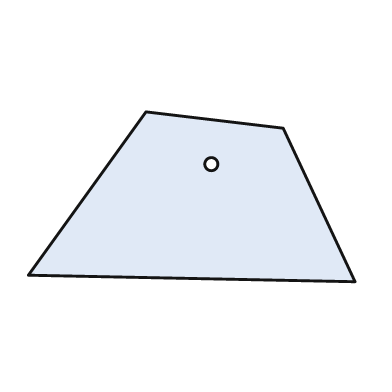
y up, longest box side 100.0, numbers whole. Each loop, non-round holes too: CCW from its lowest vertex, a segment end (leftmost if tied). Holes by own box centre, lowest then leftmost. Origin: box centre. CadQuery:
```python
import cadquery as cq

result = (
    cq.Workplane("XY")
    .moveTo(50.0, -26.0)
    .lineTo(28.0, 21.0)
    .lineTo(-14.0, 26.0)
    .lineTo(-50.0, -24.0)
    .close()
    .moveTo(6.0, 10.0)
    .circle(2.0)
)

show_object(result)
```